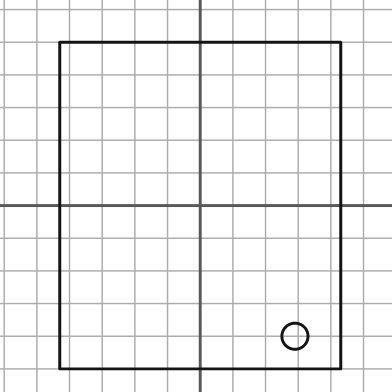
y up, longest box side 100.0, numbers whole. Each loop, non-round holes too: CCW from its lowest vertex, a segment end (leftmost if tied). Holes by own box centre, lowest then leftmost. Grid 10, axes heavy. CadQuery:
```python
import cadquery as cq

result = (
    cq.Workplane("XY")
    .moveTo(-43.0, -50.0)
    .lineTo(43.0, -50.0)
    .lineTo(43.0, 50.0)
    .lineTo(-43.0, 50.0)
    .close()
    .moveTo(29.0, -40.0)
    .circle(4.0)
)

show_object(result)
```